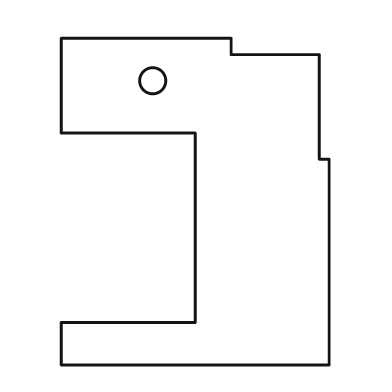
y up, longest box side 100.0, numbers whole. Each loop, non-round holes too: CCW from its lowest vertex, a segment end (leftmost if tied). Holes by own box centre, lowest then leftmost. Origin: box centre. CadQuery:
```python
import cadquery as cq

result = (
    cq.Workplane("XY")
    .moveTo(-41.0, -50.0)
    .lineTo(41.0, -50.0)
    .lineTo(41.0, 13.0)
    .lineTo(38.0, 13.0)
    .lineTo(38.0, 45.0)
    .lineTo(11.0, 45.0)
    .lineTo(11.0, 50.0)
    .lineTo(-41.0, 50.0)
    .lineTo(-41.0, 21.0)
    .lineTo(0.0, 21.0)
    .lineTo(0.0, -37.0)
    .lineTo(-41.0, -37.0)
    .close()
    .moveTo(-13.0, 37.0)
    .circle(4.0)
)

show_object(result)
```